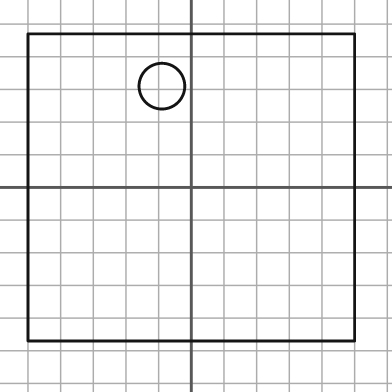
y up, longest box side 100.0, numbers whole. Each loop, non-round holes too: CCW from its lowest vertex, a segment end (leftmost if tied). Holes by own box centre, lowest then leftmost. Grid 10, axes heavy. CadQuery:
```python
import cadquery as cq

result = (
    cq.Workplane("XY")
    .moveTo(-50.0, -47.0)
    .lineTo(50.0, -47.0)
    .lineTo(50.0, 47.0)
    .lineTo(-50.0, 47.0)
    .close()
    .moveTo(-9.0, 31.0)
    .circle(7.0)
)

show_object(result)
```